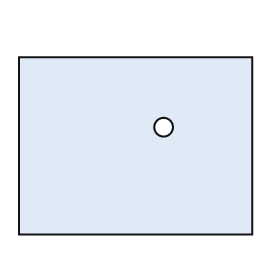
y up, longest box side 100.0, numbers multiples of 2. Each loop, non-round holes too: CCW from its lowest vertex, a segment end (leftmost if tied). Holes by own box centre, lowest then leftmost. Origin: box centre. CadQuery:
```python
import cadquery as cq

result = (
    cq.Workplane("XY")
    .moveTo(-50.0, -38.0)
    .lineTo(50.0, -38.0)
    .lineTo(50.0, 38.0)
    .lineTo(-50.0, 38.0)
    .close()
    .moveTo(12.0, 8.0)
    .circle(4.0)
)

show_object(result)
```